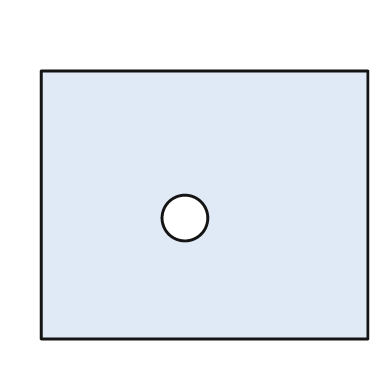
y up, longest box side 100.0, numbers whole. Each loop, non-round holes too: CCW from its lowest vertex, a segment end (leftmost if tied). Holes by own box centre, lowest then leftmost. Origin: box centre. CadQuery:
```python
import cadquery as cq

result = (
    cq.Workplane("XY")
    .moveTo(-50.0, -41.0)
    .lineTo(50.0, -41.0)
    .lineTo(50.0, 41.0)
    .lineTo(-50.0, 41.0)
    .close()
    .moveTo(-6.0, -4.0)
    .circle(7.0)
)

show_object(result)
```